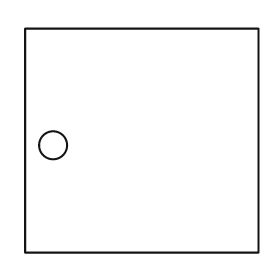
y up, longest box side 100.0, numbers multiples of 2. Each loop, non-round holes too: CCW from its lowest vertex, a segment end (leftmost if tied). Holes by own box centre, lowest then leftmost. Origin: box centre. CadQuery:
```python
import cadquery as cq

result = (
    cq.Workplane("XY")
    .moveTo(-50.0, -48.0)
    .lineTo(50.0, -48.0)
    .lineTo(50.0, 48.0)
    .lineTo(-50.0, 48.0)
    .close()
    .moveTo(-38.0, -2.0)
    .circle(6.0)
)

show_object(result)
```